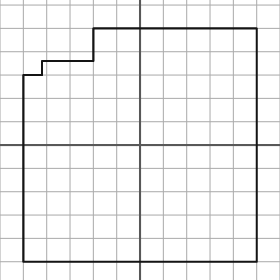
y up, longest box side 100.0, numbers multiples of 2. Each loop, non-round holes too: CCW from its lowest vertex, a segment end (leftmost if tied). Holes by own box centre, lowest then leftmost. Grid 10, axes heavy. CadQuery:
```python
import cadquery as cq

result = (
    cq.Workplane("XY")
    .moveTo(-50.0, -50.0)
    .lineTo(50.0, -50.0)
    .lineTo(50.0, 50.0)
    .lineTo(-20.0, 50.0)
    .lineTo(-20.0, 36.0)
    .lineTo(-42.0, 36.0)
    .lineTo(-42.0, 30.0)
    .lineTo(-50.0, 30.0)
    .close()
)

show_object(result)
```